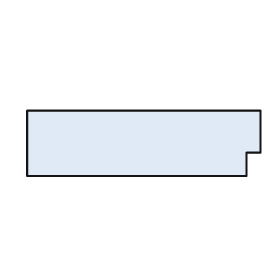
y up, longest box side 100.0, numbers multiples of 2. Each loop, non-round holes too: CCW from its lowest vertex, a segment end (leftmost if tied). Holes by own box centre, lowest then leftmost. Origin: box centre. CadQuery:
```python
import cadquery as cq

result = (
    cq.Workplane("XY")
    .moveTo(-50.0, -14.0)
    .lineTo(44.0, -14.0)
    .lineTo(44.0, -4.0)
    .lineTo(50.0, -4.0)
    .lineTo(50.0, 14.0)
    .lineTo(-50.0, 14.0)
    .close()
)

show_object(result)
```